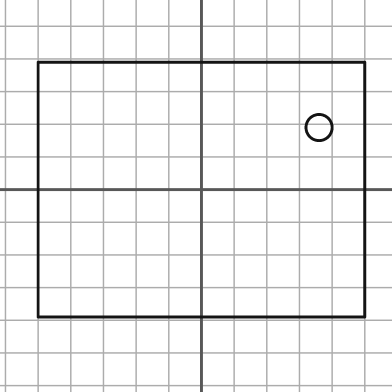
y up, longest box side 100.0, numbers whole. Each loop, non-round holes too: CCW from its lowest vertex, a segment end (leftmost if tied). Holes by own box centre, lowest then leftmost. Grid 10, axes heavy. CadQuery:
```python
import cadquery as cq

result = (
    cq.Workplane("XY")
    .moveTo(-50.0, -39.0)
    .lineTo(50.0, -39.0)
    .lineTo(50.0, 39.0)
    .lineTo(-50.0, 39.0)
    .close()
    .moveTo(36.0, 19.0)
    .circle(4.0)
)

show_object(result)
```